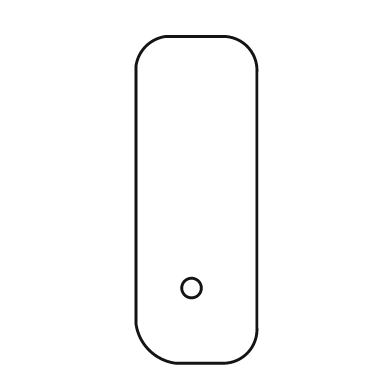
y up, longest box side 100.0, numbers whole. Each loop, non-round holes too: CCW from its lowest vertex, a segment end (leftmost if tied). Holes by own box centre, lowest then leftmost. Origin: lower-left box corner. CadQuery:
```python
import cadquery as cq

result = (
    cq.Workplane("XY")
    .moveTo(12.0, 0.0)
    .lineTo(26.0, 0.0)
    .threePointArc((34.0, 3.0), (37.0, 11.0))
    .lineTo(37.0, 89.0)
    .threePointArc((34.0, 97.0), (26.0, 100.0))
    .lineTo(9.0, 100.0)
    .threePointArc((3.0, 97.0), (0.0, 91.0))
    .lineTo(0.0, 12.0)
    .threePointArc((4.0, 4.0), (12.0, 0.0))
    .close()
    .moveTo(17.0, 23.0)
    .circle(3.0)
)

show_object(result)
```